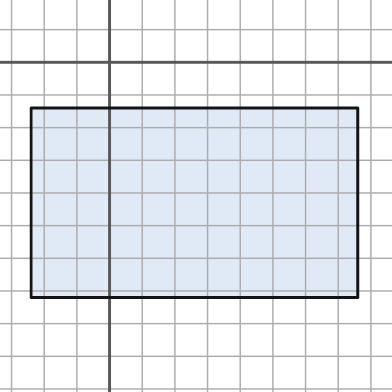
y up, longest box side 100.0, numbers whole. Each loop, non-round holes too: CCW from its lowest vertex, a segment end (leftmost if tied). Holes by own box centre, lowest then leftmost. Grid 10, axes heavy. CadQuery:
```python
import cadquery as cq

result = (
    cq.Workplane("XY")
    .moveTo(-24.0, -72.0)
    .lineTo(76.0, -72.0)
    .lineTo(76.0, -14.0)
    .lineTo(-24.0, -14.0)
    .close()
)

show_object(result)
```